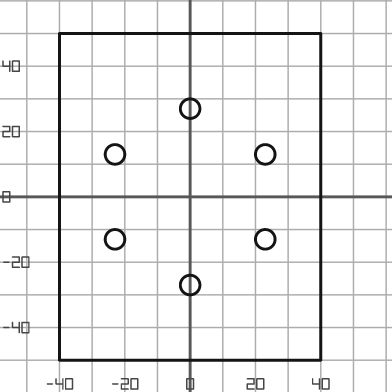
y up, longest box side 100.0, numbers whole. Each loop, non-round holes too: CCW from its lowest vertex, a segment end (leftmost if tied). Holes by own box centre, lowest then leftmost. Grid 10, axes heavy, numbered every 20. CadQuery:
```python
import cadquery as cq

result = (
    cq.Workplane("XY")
    .moveTo(-40.0, -50.0)
    .lineTo(40.0, -50.0)
    .lineTo(40.0, 50.0)
    .lineTo(-40.0, 50.0)
    .close()
    .moveTo(0.0, -27.0)
    .circle(3.0)
    .moveTo(-23.0, -13.0)
    .circle(3.0)
    .moveTo(23.0, -13.0)
    .circle(3.0)
    .moveTo(-23.0, 13.0)
    .circle(3.0)
    .moveTo(23.0, 13.0)
    .circle(3.0)
    .moveTo(0.0, 27.0)
    .circle(3.0)
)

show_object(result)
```